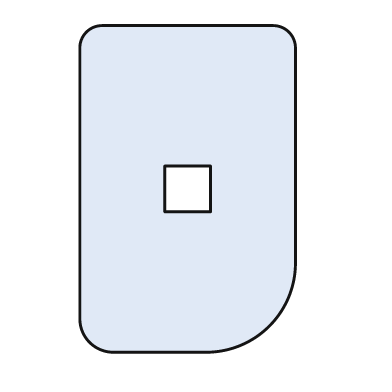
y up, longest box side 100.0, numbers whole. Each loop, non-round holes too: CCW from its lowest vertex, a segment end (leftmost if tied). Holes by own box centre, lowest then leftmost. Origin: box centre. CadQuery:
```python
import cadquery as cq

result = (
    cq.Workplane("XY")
    .moveTo(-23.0, -50.0)
    .lineTo(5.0, -50.0)
    .threePointArc((25.0, -42.0), (33.0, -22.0))
    .lineTo(33.0, 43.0)
    .threePointArc((31.0, 48.0), (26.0, 50.0))
    .lineTo(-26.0, 50.0)
    .threePointArc((-31.0, 48.0), (-33.0, 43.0))
    .lineTo(-33.0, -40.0)
    .threePointArc((-30.0, -47.0), (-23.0, -50.0))
    .close()
    .moveTo(-7.0, -7.0)
    .lineTo(7.0, -7.0)
    .lineTo(7.0, 7.0)
    .lineTo(-7.0, 7.0)
    .close()
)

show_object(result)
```